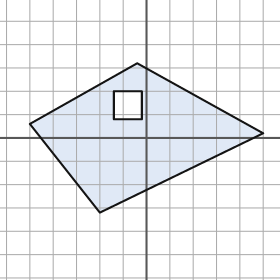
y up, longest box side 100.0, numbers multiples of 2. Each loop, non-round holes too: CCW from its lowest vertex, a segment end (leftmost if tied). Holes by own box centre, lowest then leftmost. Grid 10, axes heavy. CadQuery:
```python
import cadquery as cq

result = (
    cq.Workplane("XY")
    .moveTo(-20.0, -32.0)
    .lineTo(50.0, 2.0)
    .lineTo(-4.0, 32.0)
    .lineTo(-50.0, 6.0)
    .close()
    .moveTo(-14.0, 8.0)
    .lineTo(-2.0, 8.0)
    .lineTo(-2.0, 20.0)
    .lineTo(-14.0, 20.0)
    .close()
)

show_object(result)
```